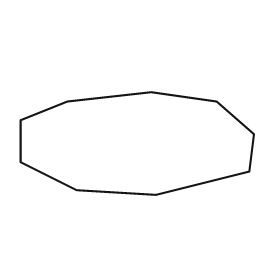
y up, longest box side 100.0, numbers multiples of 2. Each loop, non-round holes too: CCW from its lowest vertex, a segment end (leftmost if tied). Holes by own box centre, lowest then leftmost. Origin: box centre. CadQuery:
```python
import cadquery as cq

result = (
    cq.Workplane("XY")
    .moveTo(8.0, -22.0)
    .lineTo(48.0, -12.0)
    .lineTo(50.0, 4.0)
    .lineTo(34.0, 18.0)
    .lineTo(6.0, 22.0)
    .lineTo(-30.0, 18.0)
    .lineTo(-50.0, 10.0)
    .lineTo(-50.0, -8.0)
    .lineTo(-26.0, -20.0)
    .close()
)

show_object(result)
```